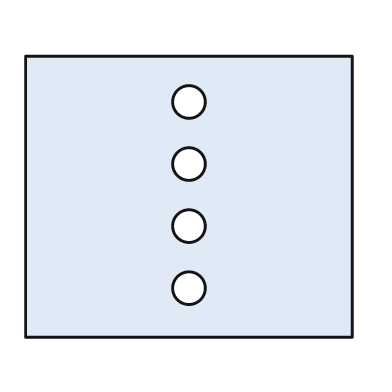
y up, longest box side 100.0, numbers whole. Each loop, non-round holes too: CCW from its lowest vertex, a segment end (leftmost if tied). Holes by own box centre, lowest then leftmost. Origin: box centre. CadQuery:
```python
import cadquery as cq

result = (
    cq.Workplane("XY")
    .moveTo(-50.0, -43.0)
    .lineTo(50.0, -43.0)
    .lineTo(50.0, 43.0)
    .lineTo(-50.0, 43.0)
    .close()
    .moveTo(0.0, -28.0)
    .circle(5.0)
    .moveTo(0.0, -9.0)
    .circle(5.0)
    .moveTo(0.0, 10.0)
    .circle(5.0)
    .moveTo(0.0, 29.0)
    .circle(5.0)
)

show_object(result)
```